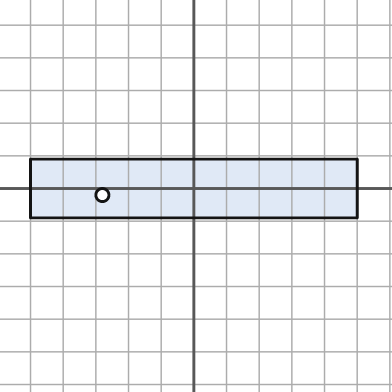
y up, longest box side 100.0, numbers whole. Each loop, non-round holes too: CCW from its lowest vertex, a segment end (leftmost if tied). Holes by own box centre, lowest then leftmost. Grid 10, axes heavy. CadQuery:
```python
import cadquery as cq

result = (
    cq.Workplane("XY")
    .moveTo(-50.0, -9.0)
    .lineTo(50.0, -9.0)
    .lineTo(50.0, 9.0)
    .lineTo(-50.0, 9.0)
    .close()
    .moveTo(-28.0, -2.0)
    .circle(2.0)
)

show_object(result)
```